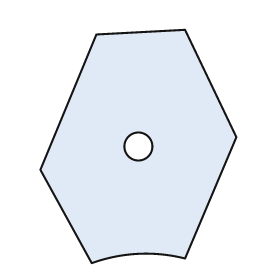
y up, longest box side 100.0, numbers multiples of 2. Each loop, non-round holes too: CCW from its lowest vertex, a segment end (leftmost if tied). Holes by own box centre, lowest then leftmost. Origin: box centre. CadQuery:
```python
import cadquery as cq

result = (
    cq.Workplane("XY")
    .moveTo(-20.0, -50.0)
    .threePointArc((0.0, -46.0), (20.0, -48.0))
    .lineTo(42.0, 4.0)
    .lineTo(20.0, 50.0)
    .lineTo(-18.0, 48.0)
    .lineTo(-42.0, -10.0)
    .close()
    .moveTo(0.0, 0.0)
    .circle(6.0)
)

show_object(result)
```